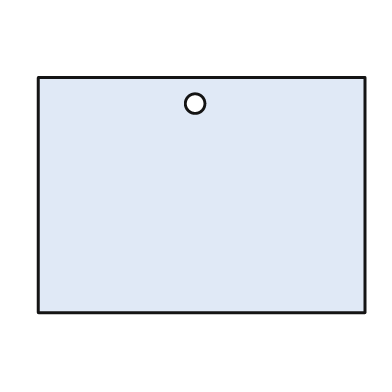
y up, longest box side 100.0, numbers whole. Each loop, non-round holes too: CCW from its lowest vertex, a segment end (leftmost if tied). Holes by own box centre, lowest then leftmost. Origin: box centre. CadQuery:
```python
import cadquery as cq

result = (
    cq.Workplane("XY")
    .moveTo(-50.0, -36.0)
    .lineTo(50.0, -36.0)
    .lineTo(50.0, 36.0)
    .lineTo(-50.0, 36.0)
    .close()
    .moveTo(-2.0, 28.0)
    .circle(3.0)
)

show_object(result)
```